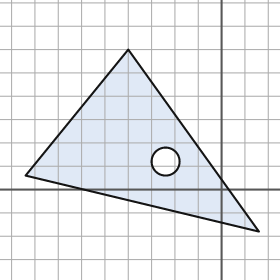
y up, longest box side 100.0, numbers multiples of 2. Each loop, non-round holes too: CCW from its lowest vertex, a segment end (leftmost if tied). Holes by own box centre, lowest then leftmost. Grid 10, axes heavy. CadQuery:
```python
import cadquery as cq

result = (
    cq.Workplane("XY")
    .moveTo(16.0, -18.0)
    .lineTo(-40.0, 60.0)
    .lineTo(-84.0, 6.0)
    .close()
    .moveTo(-24.0, 12.0)
    .circle(6.0)
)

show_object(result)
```